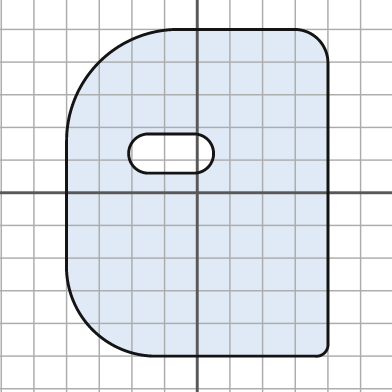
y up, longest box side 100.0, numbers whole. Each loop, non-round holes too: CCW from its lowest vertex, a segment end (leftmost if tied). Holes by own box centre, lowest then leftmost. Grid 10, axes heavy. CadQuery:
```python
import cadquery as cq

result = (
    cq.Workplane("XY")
    .moveTo(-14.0, -50.0)
    .lineTo(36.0, -50.0)
    .threePointArc((39.0, -49.0), (40.0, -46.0))
    .lineTo(40.0, 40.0)
    .threePointArc((37.0, 47.0), (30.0, 50.0))
    .lineTo(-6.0, 50.0)
    .threePointArc((-30.0, 40.0), (-40.0, 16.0))
    .lineTo(-40.0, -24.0)
    .threePointArc((-32.0, -42.0), (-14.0, -50.0))
    .close()
    .moveTo(-15.0, 6.0)
    .lineTo(-1.0, 6.0)
    .threePointArc((5.0, 12.0), (-1.0, 18.0))
    .lineTo(-15.0, 18.0)
    .threePointArc((-21.0, 12.0), (-15.0, 6.0))
    .close()
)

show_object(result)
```